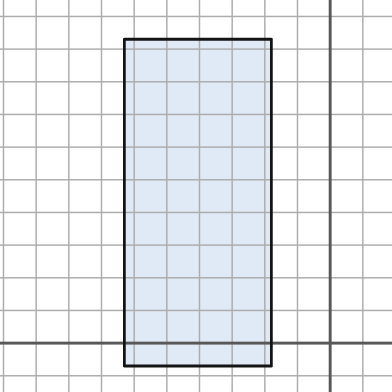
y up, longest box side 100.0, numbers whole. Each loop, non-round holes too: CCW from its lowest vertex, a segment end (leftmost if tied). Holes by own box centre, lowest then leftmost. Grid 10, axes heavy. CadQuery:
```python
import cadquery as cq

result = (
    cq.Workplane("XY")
    .moveTo(-63.0, -7.0)
    .lineTo(-18.0, -7.0)
    .lineTo(-18.0, 93.0)
    .lineTo(-63.0, 93.0)
    .close()
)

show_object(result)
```